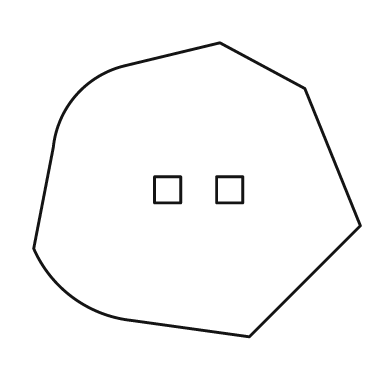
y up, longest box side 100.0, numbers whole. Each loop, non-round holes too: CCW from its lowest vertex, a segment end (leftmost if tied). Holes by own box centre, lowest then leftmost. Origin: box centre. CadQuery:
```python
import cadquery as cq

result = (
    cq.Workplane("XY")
    .moveTo(16.0, -45.0)
    .lineTo(50.0, -11.0)
    .lineTo(33.0, 31.0)
    .lineTo(7.0, 45.0)
    .lineTo(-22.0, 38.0)
    .threePointArc((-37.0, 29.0), (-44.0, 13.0))
    .lineTo(-50.0, -18.0)
    .threePointArc((-38.0, -33.0), (-20.0, -40.0))
    .close()
    .moveTo(-13.0, -4.0)
    .lineTo(-5.0, -4.0)
    .lineTo(-5.0, 4.0)
    .lineTo(-13.0, 4.0)
    .close()
    .moveTo(6.0, -4.0)
    .lineTo(14.0, -4.0)
    .lineTo(14.0, 4.0)
    .lineTo(6.0, 4.0)
    .close()
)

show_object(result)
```